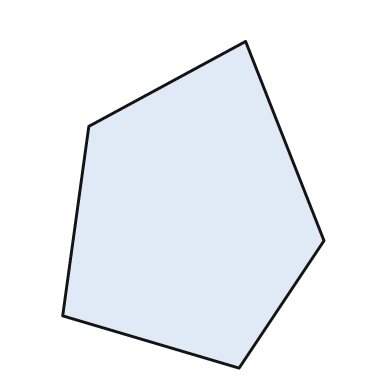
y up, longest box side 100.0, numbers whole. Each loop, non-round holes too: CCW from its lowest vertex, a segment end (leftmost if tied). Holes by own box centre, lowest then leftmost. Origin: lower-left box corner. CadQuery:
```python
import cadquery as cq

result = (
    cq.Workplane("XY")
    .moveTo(54.0, 0.0)
    .lineTo(80.0, 39.0)
    .lineTo(56.0, 100.0)
    .lineTo(8.0, 74.0)
    .lineTo(0.0, 16.0)
    .close()
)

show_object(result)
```